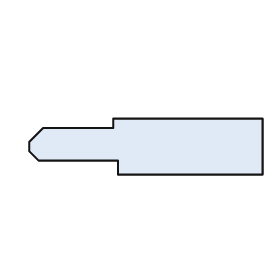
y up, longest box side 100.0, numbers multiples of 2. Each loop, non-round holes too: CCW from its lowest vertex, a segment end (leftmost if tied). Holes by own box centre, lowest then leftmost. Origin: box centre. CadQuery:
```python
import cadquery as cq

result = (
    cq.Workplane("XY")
    .moveTo(-12.0, -12.0)
    .lineTo(50.0, -12.0)
    .lineTo(50.0, 12.0)
    .lineTo(-14.0, 12.0)
    .lineTo(-14.0, 8.0)
    .lineTo(-44.0, 8.0)
    .lineTo(-50.0, 2.0)
    .lineTo(-50.0, -2.0)
    .lineTo(-46.0, -6.0)
    .lineTo(-12.0, -6.0)
    .close()
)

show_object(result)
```